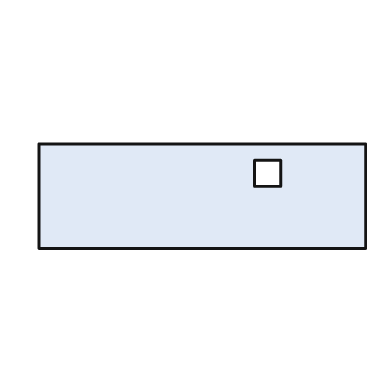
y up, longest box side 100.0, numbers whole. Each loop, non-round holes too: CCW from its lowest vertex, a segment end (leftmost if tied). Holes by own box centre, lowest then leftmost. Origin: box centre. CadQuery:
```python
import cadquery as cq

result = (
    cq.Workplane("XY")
    .moveTo(-50.0, -16.0)
    .lineTo(50.0, -16.0)
    .lineTo(50.0, 16.0)
    .lineTo(-50.0, 16.0)
    .close()
    .moveTo(16.0, 3.0)
    .lineTo(24.0, 3.0)
    .lineTo(24.0, 11.0)
    .lineTo(16.0, 11.0)
    .close()
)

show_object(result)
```